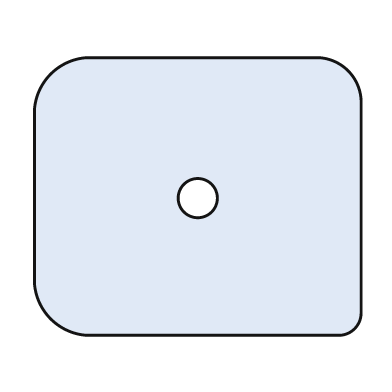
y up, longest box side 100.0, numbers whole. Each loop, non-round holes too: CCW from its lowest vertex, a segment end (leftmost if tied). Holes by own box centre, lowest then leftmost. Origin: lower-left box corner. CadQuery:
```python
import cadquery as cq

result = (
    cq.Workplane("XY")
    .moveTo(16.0, 0.0)
    .lineTo(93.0, 0.0)
    .threePointArc((98.0, 2.0), (100.0, 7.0))
    .lineTo(100.0, 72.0)
    .threePointArc((96.0, 81.0), (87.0, 85.0))
    .lineTo(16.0, 85.0)
    .threePointArc((5.0, 80.0), (0.0, 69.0))
    .lineTo(0.0, 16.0)
    .threePointArc((5.0, 5.0), (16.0, 0.0))
    .close()
    .moveTo(50.0, 42.0)
    .circle(6.0)
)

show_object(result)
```